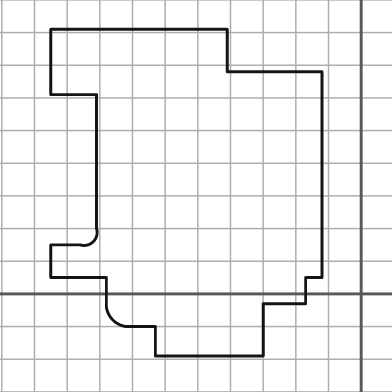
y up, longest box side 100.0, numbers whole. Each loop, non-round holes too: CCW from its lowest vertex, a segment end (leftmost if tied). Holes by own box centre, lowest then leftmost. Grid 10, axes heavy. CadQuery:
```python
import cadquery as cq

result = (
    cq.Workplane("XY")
    .moveTo(-63.0, -19.0)
    .lineTo(-30.0, -19.0)
    .lineTo(-30.0, -3.0)
    .lineTo(-17.0, -3.0)
    .lineTo(-17.0, 5.0)
    .lineTo(-12.0, 5.0)
    .lineTo(-12.0, 68.0)
    .lineTo(-41.0, 68.0)
    .lineTo(-41.0, 81.0)
    .lineTo(-95.0, 81.0)
    .lineTo(-95.0, 61.0)
    .lineTo(-81.0, 61.0)
    .lineTo(-81.0, 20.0)
    .threePointArc((-82.0, 16.0), (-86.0, 15.0))
    .lineTo(-95.0, 15.0)
    .lineTo(-95.0, 5.0)
    .lineTo(-78.0, 5.0)
    .lineTo(-78.0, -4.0)
    .threePointArc((-76.0, -8.0), (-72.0, -10.0))
    .lineTo(-63.0, -10.0)
    .close()
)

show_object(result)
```